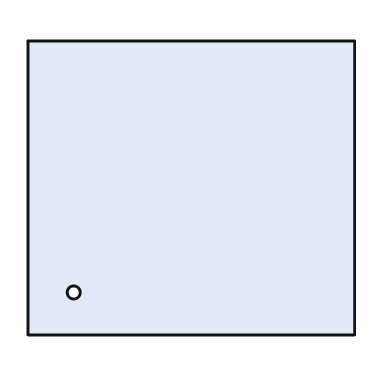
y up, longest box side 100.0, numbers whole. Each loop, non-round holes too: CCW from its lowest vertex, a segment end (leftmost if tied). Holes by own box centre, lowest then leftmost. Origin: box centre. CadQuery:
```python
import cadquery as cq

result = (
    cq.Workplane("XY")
    .moveTo(-50.0, -45.0)
    .lineTo(50.0, -45.0)
    .lineTo(50.0, 45.0)
    .lineTo(-50.0, 45.0)
    .close()
    .moveTo(-36.0, -32.0)
    .circle(2.0)
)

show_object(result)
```